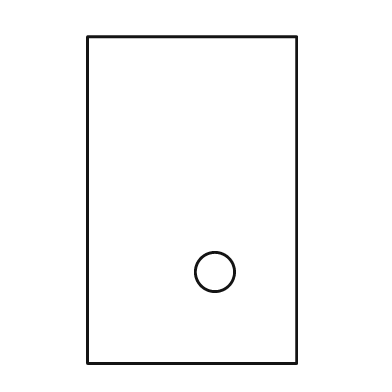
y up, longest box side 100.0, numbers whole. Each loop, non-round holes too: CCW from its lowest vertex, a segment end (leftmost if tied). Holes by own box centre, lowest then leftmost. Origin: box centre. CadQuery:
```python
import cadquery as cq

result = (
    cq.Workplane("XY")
    .moveTo(-32.0, -50.0)
    .lineTo(32.0, -50.0)
    .lineTo(32.0, 50.0)
    .lineTo(-32.0, 50.0)
    .close()
    .moveTo(7.0, -22.0)
    .circle(6.0)
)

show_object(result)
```